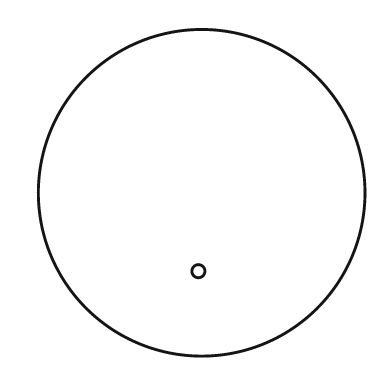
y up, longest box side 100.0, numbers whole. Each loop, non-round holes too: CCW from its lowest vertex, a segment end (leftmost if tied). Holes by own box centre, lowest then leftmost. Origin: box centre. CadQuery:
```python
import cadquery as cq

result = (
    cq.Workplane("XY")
    .moveTo(0.0, 0.0)
    .circle(50.0)
    .moveTo(-1.0, -24.0)
    .circle(2.0)
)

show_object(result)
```